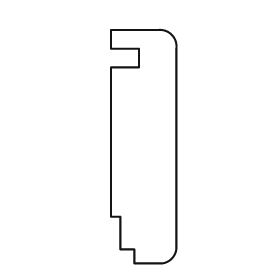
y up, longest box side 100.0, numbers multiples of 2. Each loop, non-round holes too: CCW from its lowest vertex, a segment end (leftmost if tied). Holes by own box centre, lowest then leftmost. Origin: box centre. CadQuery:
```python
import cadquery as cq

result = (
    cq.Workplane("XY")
    .moveTo(-4.0, -50.0)
    .lineTo(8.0, -50.0)
    .threePointArc((12.0, -48.0), (14.0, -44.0))
    .lineTo(14.0, 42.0)
    .threePointArc((12.0, 48.0), (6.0, 50.0))
    .lineTo(-14.0, 50.0)
    .lineTo(-14.0, 42.0)
    .lineTo(-2.0, 42.0)
    .lineTo(-2.0, 34.0)
    .lineTo(-14.0, 34.0)
    .lineTo(-14.0, -30.0)
    .lineTo(-10.0, -30.0)
    .lineTo(-10.0, -44.0)
    .lineTo(-4.0, -44.0)
    .close()
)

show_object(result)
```